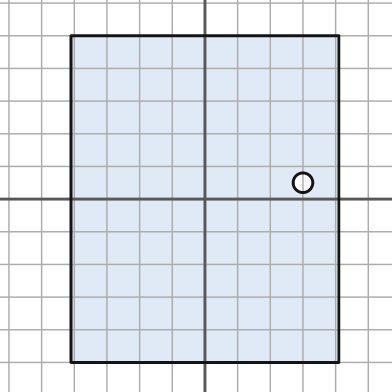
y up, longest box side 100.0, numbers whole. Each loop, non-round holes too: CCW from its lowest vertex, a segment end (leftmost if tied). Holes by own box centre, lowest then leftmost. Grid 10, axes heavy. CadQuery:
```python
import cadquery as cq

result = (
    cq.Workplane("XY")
    .moveTo(-41.0, -50.0)
    .lineTo(41.0, -50.0)
    .lineTo(41.0, 50.0)
    .lineTo(-41.0, 50.0)
    .close()
    .moveTo(30.0, 5.0)
    .circle(3.0)
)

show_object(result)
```